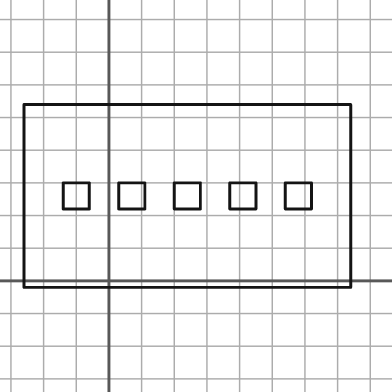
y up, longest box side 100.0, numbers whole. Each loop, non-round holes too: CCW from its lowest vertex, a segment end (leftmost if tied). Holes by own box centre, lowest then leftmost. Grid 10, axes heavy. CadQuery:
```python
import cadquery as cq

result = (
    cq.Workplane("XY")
    .moveTo(-26.0, -2.0)
    .lineTo(74.0, -2.0)
    .lineTo(74.0, 54.0)
    .lineTo(-26.0, 54.0)
    .close()
    .moveTo(-14.0, 22.0)
    .lineTo(-6.0, 22.0)
    .lineTo(-6.0, 30.0)
    .lineTo(-14.0, 30.0)
    .close()
    .moveTo(3.0, 22.0)
    .lineTo(11.0, 22.0)
    .lineTo(11.0, 30.0)
    .lineTo(3.0, 30.0)
    .close()
    .moveTo(20.0, 22.0)
    .lineTo(28.0, 22.0)
    .lineTo(28.0, 30.0)
    .lineTo(20.0, 30.0)
    .close()
    .moveTo(37.0, 22.0)
    .lineTo(45.0, 22.0)
    .lineTo(45.0, 30.0)
    .lineTo(37.0, 30.0)
    .close()
    .moveTo(54.0, 22.0)
    .lineTo(62.0, 22.0)
    .lineTo(62.0, 30.0)
    .lineTo(54.0, 30.0)
    .close()
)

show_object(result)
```